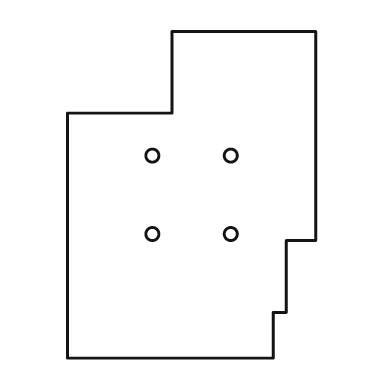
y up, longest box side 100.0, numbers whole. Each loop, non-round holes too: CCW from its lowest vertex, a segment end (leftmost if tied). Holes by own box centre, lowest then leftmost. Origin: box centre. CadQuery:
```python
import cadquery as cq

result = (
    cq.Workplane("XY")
    .moveTo(-38.0, -50.0)
    .lineTo(25.0, -50.0)
    .lineTo(25.0, -36.0)
    .lineTo(29.0, -36.0)
    .lineTo(29.0, -14.0)
    .lineTo(38.0, -14.0)
    .lineTo(38.0, 50.0)
    .lineTo(-6.0, 50.0)
    .lineTo(-6.0, 25.0)
    .lineTo(-38.0, 25.0)
    .close()
    .moveTo(-12.0, -12.0)
    .circle(2.0)
    .moveTo(12.0, -12.0)
    .circle(2.0)
    .moveTo(-12.0, 12.0)
    .circle(2.0)
    .moveTo(12.0, 12.0)
    .circle(2.0)
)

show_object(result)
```